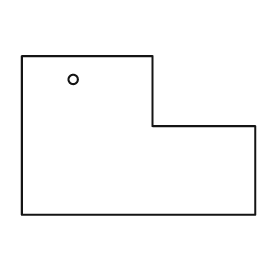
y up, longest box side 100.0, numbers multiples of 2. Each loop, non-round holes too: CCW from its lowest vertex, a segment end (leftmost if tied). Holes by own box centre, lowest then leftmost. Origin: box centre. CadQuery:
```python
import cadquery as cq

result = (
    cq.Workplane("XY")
    .moveTo(-50.0, -34.0)
    .lineTo(50.0, -34.0)
    .lineTo(50.0, 4.0)
    .lineTo(6.0, 4.0)
    .lineTo(6.0, 34.0)
    .lineTo(-50.0, 34.0)
    .close()
    .moveTo(-28.0, 24.0)
    .circle(2.0)
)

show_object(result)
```